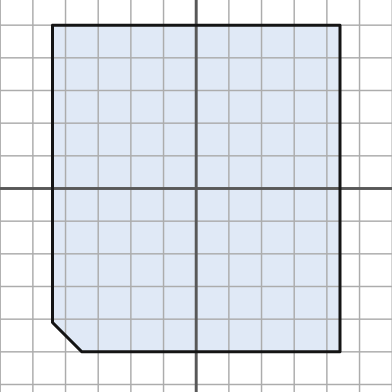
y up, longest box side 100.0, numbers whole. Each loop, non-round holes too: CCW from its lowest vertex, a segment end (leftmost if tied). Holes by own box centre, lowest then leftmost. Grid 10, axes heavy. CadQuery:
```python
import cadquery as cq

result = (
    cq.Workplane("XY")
    .moveTo(-35.0, -50.0)
    .lineTo(44.0, -50.0)
    .lineTo(44.0, 50.0)
    .lineTo(-44.0, 50.0)
    .lineTo(-44.0, -41.0)
    .close()
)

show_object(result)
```